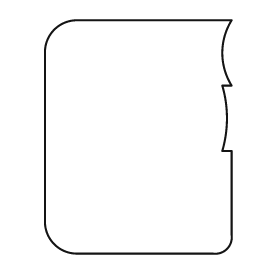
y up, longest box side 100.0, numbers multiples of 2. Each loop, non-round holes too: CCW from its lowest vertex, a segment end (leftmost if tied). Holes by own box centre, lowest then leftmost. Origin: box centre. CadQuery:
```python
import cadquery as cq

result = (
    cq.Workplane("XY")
    .moveTo(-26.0, -50.0)
    .lineTo(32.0, -50.0)
    .threePointArc((38.0, -48.0), (40.0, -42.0))
    .lineTo(40.0, -6.0)
    .lineTo(36.0, -6.0)
    .threePointArc((38.0, 8.0), (36.0, 22.0))
    .lineTo(40.0, 22.0)
    .threePointArc((36.0, 36.0), (40.0, 50.0))
    .lineTo(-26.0, 50.0)
    .threePointArc((-36.0, 46.0), (-40.0, 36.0))
    .lineTo(-40.0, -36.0)
    .threePointArc((-36.0, -46.0), (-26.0, -50.0))
    .close()
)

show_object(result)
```